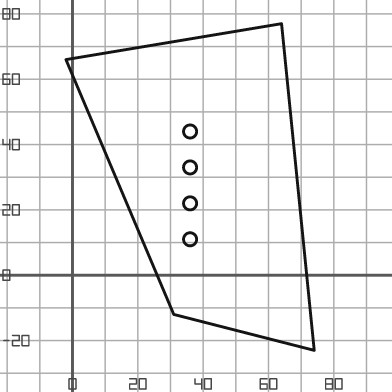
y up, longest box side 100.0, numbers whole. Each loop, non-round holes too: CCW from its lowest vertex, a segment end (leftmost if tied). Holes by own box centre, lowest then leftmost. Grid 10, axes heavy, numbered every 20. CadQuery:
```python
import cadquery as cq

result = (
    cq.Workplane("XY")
    .moveTo(74.0, -23.0)
    .lineTo(64.0, 77.0)
    .lineTo(-2.0, 66.0)
    .lineTo(31.0, -12.0)
    .close()
    .moveTo(36.0, 11.0)
    .circle(2.0)
    .moveTo(36.0, 22.0)
    .circle(2.0)
    .moveTo(36.0, 33.0)
    .circle(2.0)
    .moveTo(36.0, 44.0)
    .circle(2.0)
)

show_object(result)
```